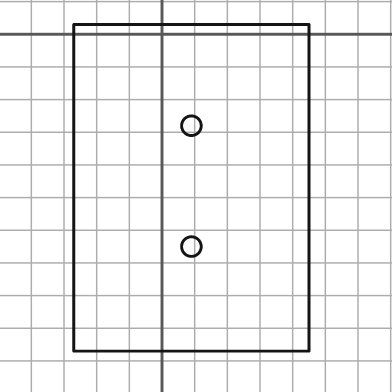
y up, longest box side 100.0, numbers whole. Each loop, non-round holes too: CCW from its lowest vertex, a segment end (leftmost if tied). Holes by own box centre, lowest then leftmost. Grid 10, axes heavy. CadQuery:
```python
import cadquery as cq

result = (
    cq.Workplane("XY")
    .moveTo(-27.0, -97.0)
    .lineTo(45.0, -97.0)
    .lineTo(45.0, 3.0)
    .lineTo(-27.0, 3.0)
    .close()
    .moveTo(9.0, -65.0)
    .circle(3.0)
    .moveTo(9.0, -28.0)
    .circle(3.0)
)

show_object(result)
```